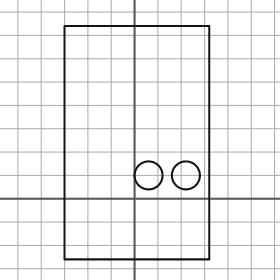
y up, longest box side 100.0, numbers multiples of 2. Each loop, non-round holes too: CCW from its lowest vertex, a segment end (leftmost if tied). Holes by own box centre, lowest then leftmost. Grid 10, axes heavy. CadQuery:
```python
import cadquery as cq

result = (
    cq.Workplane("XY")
    .moveTo(-30.0, -26.0)
    .lineTo(32.0, -26.0)
    .lineTo(32.0, 74.0)
    .lineTo(-30.0, 74.0)
    .close()
    .moveTo(6.0, 10.0)
    .circle(6.0)
    .moveTo(22.0, 10.0)
    .circle(6.0)
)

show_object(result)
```